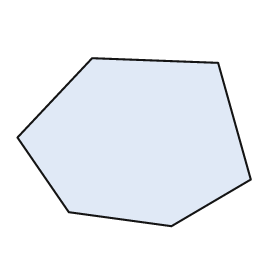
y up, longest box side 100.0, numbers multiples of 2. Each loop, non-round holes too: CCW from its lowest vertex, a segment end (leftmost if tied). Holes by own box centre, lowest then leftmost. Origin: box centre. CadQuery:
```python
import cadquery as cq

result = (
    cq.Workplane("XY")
    .moveTo(16.0, -36.0)
    .lineTo(50.0, -16.0)
    .lineTo(36.0, 34.0)
    .lineTo(-18.0, 36.0)
    .lineTo(-50.0, 2.0)
    .lineTo(-28.0, -30.0)
    .close()
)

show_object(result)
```